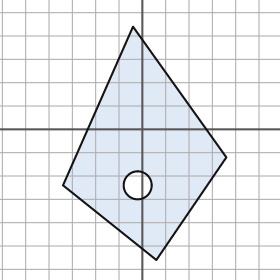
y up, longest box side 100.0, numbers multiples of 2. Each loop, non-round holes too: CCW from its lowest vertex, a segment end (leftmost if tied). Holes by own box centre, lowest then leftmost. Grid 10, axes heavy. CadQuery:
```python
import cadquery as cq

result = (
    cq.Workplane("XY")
    .moveTo(6.0, -56.0)
    .lineTo(36.0, -12.0)
    .lineTo(-4.0, 44.0)
    .lineTo(-34.0, -24.0)
    .close()
    .moveTo(-2.0, -24.0)
    .circle(6.0)
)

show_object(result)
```